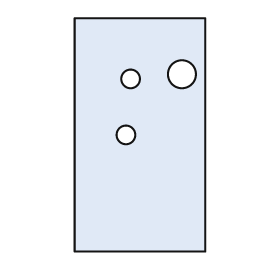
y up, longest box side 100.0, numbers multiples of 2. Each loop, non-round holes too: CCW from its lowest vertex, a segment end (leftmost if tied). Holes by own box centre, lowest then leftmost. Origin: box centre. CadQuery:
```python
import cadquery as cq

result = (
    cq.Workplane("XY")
    .moveTo(-28.0, -50.0)
    .lineTo(28.0, -50.0)
    .lineTo(28.0, 50.0)
    .lineTo(-28.0, 50.0)
    .close()
    .moveTo(-6.0, 0.0)
    .circle(4.0)
    .moveTo(-4.0, 24.0)
    .circle(4.0)
    .moveTo(18.0, 26.0)
    .circle(6.0)
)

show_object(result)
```